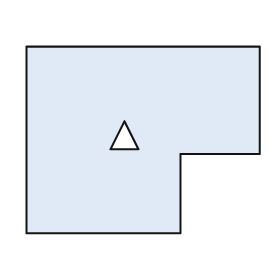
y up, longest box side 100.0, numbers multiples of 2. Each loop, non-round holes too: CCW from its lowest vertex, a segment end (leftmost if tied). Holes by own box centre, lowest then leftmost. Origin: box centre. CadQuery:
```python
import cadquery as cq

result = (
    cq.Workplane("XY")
    .moveTo(-50.0, -40.0)
    .lineTo(16.0, -40.0)
    .lineTo(16.0, -6.0)
    .lineTo(50.0, -6.0)
    .lineTo(50.0, 40.0)
    .lineTo(-50.0, 40.0)
    .close()
    .moveTo(-14.0, -4.0)
    .lineTo(-2.0, -4.0)
    .lineTo(-8.0, 8.0)
    .close()
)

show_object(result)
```